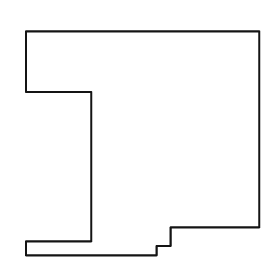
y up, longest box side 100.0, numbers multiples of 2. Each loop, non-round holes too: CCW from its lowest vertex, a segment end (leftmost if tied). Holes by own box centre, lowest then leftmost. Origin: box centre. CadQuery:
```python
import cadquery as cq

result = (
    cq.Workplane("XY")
    .moveTo(-50.0, -48.0)
    .lineTo(6.0, -48.0)
    .lineTo(6.0, -44.0)
    .lineTo(12.0, -44.0)
    .lineTo(12.0, -36.0)
    .lineTo(50.0, -36.0)
    .lineTo(50.0, 48.0)
    .lineTo(-50.0, 48.0)
    .lineTo(-50.0, 22.0)
    .lineTo(-22.0, 22.0)
    .lineTo(-22.0, -42.0)
    .lineTo(-50.0, -42.0)
    .close()
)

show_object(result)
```